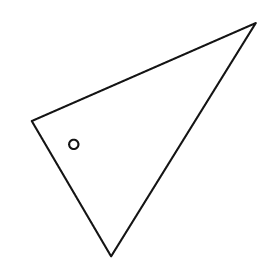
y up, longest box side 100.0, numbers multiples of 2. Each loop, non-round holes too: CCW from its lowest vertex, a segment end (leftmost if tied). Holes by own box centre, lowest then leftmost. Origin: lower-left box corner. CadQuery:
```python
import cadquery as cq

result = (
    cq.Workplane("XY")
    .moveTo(34.0, 0.0)
    .lineTo(96.0, 100.0)
    .lineTo(0.0, 58.0)
    .close()
    .moveTo(18.0, 48.0)
    .circle(2.0)
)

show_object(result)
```